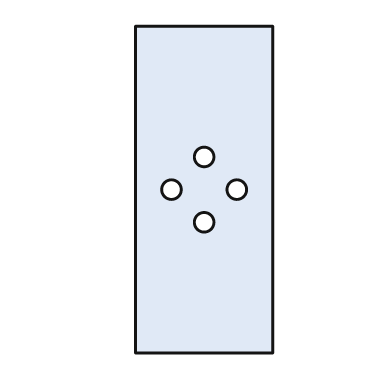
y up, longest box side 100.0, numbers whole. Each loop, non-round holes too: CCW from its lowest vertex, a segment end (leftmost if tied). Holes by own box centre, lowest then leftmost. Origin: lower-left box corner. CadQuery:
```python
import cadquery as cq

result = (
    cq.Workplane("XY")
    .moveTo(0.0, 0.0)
    .lineTo(42.0, 0.0)
    .lineTo(42.0, 100.0)
    .lineTo(0.0, 100.0)
    .close()
    .moveTo(21.0, 40.0)
    .circle(3.0)
    .moveTo(11.0, 50.0)
    .circle(3.0)
    .moveTo(31.0, 50.0)
    .circle(3.0)
    .moveTo(21.0, 60.0)
    .circle(3.0)
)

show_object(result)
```